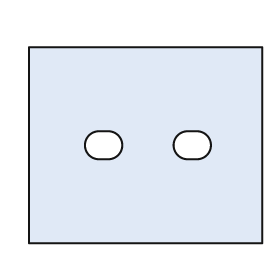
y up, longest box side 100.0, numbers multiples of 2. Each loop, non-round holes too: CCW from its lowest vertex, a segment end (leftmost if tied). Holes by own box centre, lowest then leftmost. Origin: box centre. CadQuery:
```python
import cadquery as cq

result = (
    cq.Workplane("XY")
    .moveTo(-50.0, -42.0)
    .lineTo(50.0, -42.0)
    .lineTo(50.0, 42.0)
    .lineTo(-50.0, 42.0)
    .close()
    .moveTo(-20.0, -6.0)
    .lineTo(-16.0, -6.0)
    .threePointArc((-10.0, 0.0), (-16.0, 6.0))
    .lineTo(-20.0, 6.0)
    .threePointArc((-26.0, 0.0), (-20.0, -6.0))
    .close()
    .moveTo(18.0, -6.0)
    .lineTo(22.0, -6.0)
    .threePointArc((28.0, 0.0), (22.0, 6.0))
    .lineTo(18.0, 6.0)
    .threePointArc((12.0, 0.0), (18.0, -6.0))
    .close()
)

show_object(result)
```